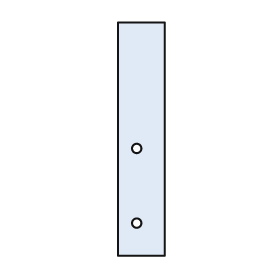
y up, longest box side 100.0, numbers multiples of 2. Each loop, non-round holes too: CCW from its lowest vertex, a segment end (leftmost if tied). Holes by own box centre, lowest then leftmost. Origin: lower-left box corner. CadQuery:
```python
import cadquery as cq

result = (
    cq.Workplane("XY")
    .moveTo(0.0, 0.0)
    .lineTo(20.0, 0.0)
    .lineTo(20.0, 100.0)
    .lineTo(0.0, 100.0)
    .close()
    .moveTo(8.0, 14.0)
    .circle(2.0)
    .moveTo(8.0, 46.0)
    .circle(2.0)
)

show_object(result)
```